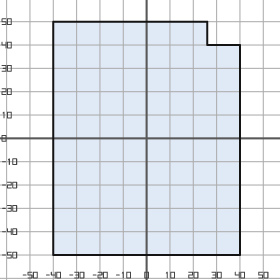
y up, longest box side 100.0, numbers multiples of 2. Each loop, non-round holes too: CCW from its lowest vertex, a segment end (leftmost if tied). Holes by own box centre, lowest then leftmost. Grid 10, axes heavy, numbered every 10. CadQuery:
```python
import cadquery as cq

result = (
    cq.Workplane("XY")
    .moveTo(-40.0, -50.0)
    .lineTo(40.0, -50.0)
    .lineTo(40.0, 40.0)
    .lineTo(26.0, 40.0)
    .lineTo(26.0, 50.0)
    .lineTo(-40.0, 50.0)
    .close()
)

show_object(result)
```